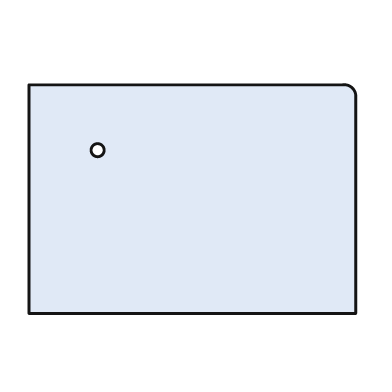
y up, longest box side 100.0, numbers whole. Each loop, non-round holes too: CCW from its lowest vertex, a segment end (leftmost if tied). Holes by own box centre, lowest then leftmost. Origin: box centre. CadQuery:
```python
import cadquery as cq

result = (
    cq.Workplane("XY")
    .moveTo(-50.0, -35.0)
    .lineTo(50.0, -35.0)
    .lineTo(50.0, 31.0)
    .threePointArc((49.0, 34.0), (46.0, 35.0))
    .lineTo(-50.0, 35.0)
    .close()
    .moveTo(-29.0, 15.0)
    .circle(2.0)
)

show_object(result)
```